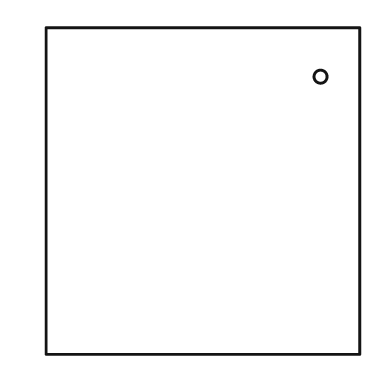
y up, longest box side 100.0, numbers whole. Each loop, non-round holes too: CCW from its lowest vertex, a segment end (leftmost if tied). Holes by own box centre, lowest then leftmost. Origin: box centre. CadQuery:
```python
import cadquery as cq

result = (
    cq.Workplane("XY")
    .moveTo(-48.0, -50.0)
    .lineTo(48.0, -50.0)
    .lineTo(48.0, 50.0)
    .lineTo(-48.0, 50.0)
    .close()
    .moveTo(36.0, 35.0)
    .circle(2.0)
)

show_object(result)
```